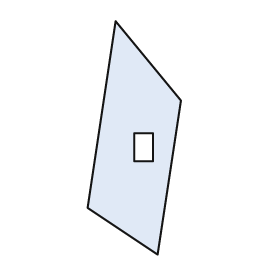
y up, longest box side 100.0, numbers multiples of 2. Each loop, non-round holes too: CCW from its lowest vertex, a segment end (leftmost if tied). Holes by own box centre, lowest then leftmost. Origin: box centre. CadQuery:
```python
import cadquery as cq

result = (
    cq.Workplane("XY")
    .moveTo(10.0, -50.0)
    .lineTo(20.0, 16.0)
    .lineTo(-8.0, 50.0)
    .lineTo(-20.0, -30.0)
    .close()
    .moveTo(0.0, -10.0)
    .lineTo(8.0, -10.0)
    .lineTo(8.0, 2.0)
    .lineTo(0.0, 2.0)
    .close()
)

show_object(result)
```